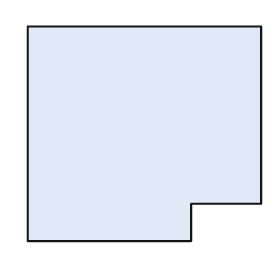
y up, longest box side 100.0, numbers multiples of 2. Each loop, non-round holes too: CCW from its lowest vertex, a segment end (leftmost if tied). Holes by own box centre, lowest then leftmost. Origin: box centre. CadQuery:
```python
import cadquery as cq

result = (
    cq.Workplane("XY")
    .moveTo(-50.0, -46.0)
    .lineTo(20.0, -46.0)
    .lineTo(20.0, -30.0)
    .lineTo(50.0, -30.0)
    .lineTo(50.0, 46.0)
    .lineTo(-50.0, 46.0)
    .close()
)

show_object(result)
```